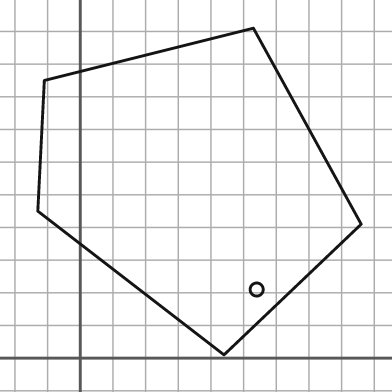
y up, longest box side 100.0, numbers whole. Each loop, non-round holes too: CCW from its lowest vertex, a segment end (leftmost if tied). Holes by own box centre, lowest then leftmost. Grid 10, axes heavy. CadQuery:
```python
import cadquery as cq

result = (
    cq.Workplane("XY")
    .moveTo(44.0, 1.0)
    .lineTo(86.0, 41.0)
    .lineTo(53.0, 101.0)
    .lineTo(-11.0, 85.0)
    .lineTo(-13.0, 45.0)
    .close()
    .moveTo(54.0, 21.0)
    .circle(2.0)
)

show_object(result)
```